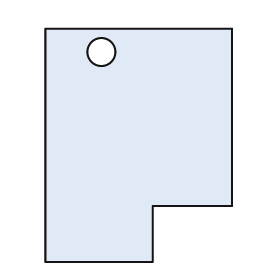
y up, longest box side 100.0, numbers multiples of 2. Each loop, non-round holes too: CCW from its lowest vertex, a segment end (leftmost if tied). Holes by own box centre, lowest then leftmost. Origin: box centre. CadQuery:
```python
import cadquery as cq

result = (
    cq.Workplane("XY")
    .moveTo(-40.0, -50.0)
    .lineTo(6.0, -50.0)
    .lineTo(6.0, -26.0)
    .lineTo(40.0, -26.0)
    .lineTo(40.0, 50.0)
    .lineTo(-40.0, 50.0)
    .close()
    .moveTo(-16.0, 40.0)
    .circle(6.0)
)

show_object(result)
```